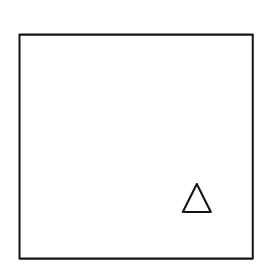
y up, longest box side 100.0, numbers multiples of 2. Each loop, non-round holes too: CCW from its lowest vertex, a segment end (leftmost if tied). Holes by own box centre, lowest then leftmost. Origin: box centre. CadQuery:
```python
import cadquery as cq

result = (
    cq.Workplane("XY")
    .moveTo(-50.0, -48.0)
    .lineTo(50.0, -48.0)
    .lineTo(50.0, 48.0)
    .lineTo(-50.0, 48.0)
    .close()
    .moveTo(20.0, -28.0)
    .lineTo(32.0, -28.0)
    .lineTo(26.0, -16.0)
    .close()
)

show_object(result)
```